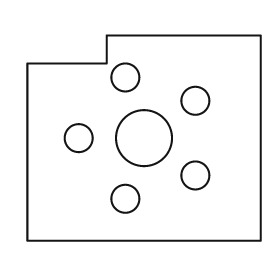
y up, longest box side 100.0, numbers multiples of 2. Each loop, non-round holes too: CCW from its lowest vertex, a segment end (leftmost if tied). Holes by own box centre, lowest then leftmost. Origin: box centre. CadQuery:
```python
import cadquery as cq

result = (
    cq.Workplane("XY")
    .moveTo(-50.0, -44.0)
    .lineTo(50.0, -44.0)
    .lineTo(50.0, 44.0)
    .lineTo(-16.0, 44.0)
    .lineTo(-16.0, 32.0)
    .lineTo(-50.0, 32.0)
    .close()
    .moveTo(-8.0, -26.0)
    .circle(6.0)
    .moveTo(22.0, -16.0)
    .circle(6.0)
    .moveTo(-28.0, 0.0)
    .circle(6.0)
    .moveTo(0.0, 0.0)
    .circle(12.0)
    .moveTo(22.0, 16.0)
    .circle(6.0)
    .moveTo(-8.0, 26.0)
    .circle(6.0)
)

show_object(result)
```